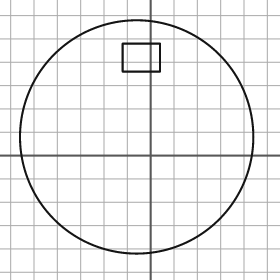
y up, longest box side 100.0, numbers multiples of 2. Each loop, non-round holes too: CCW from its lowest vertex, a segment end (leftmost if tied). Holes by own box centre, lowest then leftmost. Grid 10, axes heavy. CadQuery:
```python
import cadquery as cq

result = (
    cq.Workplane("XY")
    .moveTo(-6.0, 8.0)
    .circle(50.0)
    .moveTo(-12.0, 36.0)
    .lineTo(4.0, 36.0)
    .lineTo(4.0, 48.0)
    .lineTo(-12.0, 48.0)
    .close()
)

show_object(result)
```